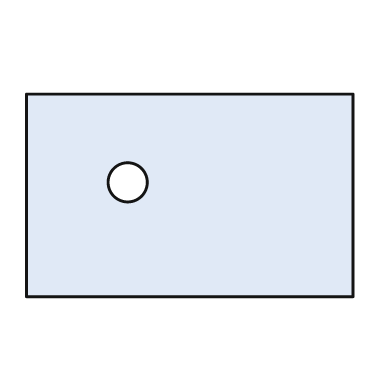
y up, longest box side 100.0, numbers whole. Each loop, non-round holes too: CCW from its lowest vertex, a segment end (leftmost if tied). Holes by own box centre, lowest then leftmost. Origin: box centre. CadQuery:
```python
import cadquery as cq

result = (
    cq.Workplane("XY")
    .moveTo(-50.0, -31.0)
    .lineTo(50.0, -31.0)
    .lineTo(50.0, 31.0)
    .lineTo(-50.0, 31.0)
    .close()
    .moveTo(-19.0, 4.0)
    .circle(6.0)
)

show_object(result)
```